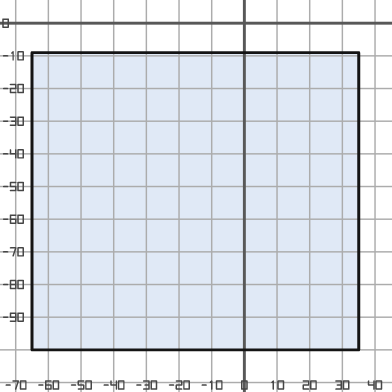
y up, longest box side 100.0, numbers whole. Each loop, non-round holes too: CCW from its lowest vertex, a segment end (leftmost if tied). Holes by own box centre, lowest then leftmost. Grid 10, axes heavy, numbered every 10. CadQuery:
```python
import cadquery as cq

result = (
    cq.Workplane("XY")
    .moveTo(-65.0, -100.0)
    .lineTo(35.0, -100.0)
    .lineTo(35.0, -9.0)
    .lineTo(-65.0, -9.0)
    .close()
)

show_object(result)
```